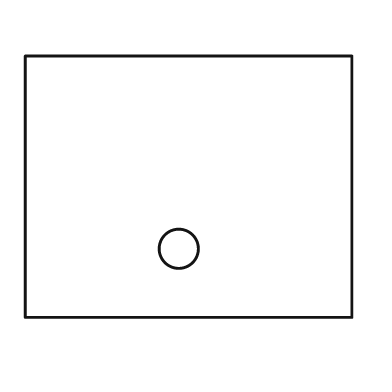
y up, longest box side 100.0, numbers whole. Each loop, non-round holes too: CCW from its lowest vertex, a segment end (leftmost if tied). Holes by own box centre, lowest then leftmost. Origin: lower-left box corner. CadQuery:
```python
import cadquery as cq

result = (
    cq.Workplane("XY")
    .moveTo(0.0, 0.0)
    .lineTo(100.0, 0.0)
    .lineTo(100.0, 80.0)
    .lineTo(0.0, 80.0)
    .close()
    .moveTo(47.0, 21.0)
    .circle(6.0)
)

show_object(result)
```